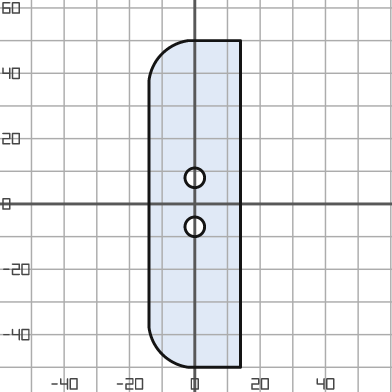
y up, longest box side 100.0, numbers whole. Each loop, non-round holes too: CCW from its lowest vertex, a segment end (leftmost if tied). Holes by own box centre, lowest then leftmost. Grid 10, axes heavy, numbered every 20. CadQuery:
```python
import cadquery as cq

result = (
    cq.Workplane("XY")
    .moveTo(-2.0, -50.0)
    .lineTo(14.0, -50.0)
    .lineTo(14.0, 50.0)
    .lineTo(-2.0, 50.0)
    .threePointArc((-10.0, 46.0), (-14.0, 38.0))
    .lineTo(-14.0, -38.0)
    .threePointArc((-10.0, -46.0), (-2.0, -50.0))
    .close()
    .moveTo(0.0, -7.0)
    .circle(3.0)
    .moveTo(0.0, 8.0)
    .circle(3.0)
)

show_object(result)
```